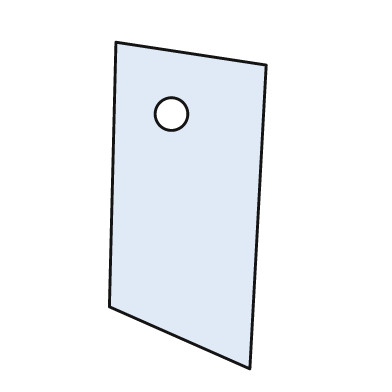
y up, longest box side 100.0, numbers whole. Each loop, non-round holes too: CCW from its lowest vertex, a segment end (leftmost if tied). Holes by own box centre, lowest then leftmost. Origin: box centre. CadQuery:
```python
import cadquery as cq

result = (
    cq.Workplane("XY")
    .moveTo(19.0, -50.0)
    .lineTo(24.0, 43.0)
    .lineTo(-22.0, 50.0)
    .lineTo(-24.0, -31.0)
    .close()
    .moveTo(-5.0, 28.0)
    .circle(5.0)
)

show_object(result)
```